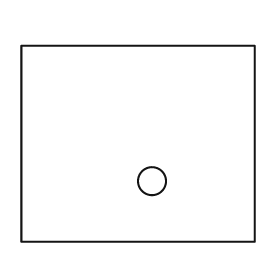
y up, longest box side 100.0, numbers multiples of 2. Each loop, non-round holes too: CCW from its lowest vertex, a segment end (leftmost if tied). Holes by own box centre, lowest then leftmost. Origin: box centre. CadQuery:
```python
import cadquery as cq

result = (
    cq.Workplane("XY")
    .moveTo(-50.0, -42.0)
    .lineTo(50.0, -42.0)
    .lineTo(50.0, 42.0)
    .lineTo(-50.0, 42.0)
    .close()
    .moveTo(6.0, -16.0)
    .circle(6.0)
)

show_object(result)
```